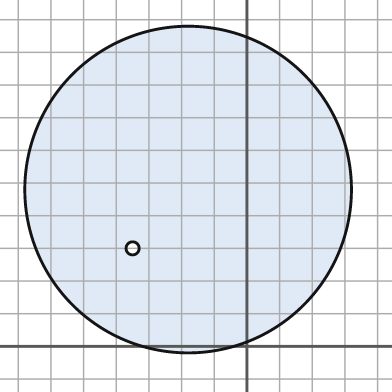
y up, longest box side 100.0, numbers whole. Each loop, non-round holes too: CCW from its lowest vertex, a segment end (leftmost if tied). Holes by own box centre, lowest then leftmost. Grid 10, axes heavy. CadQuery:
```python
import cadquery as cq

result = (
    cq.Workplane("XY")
    .moveTo(-18.0, 48.0)
    .circle(50.0)
    .moveTo(-35.0, 30.0)
    .circle(2.0)
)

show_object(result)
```